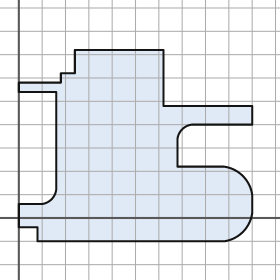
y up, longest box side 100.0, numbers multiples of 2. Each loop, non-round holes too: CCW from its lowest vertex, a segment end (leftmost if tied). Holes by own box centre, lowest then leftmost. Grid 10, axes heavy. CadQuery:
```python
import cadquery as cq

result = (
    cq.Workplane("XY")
    .moveTo(8.0, -10.0)
    .lineTo(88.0, -10.0)
    .threePointArc((96.0, -6.0), (100.0, 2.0))
    .lineTo(100.0, 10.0)
    .threePointArc((96.0, 18.0), (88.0, 22.0))
    .lineTo(68.0, 22.0)
    .lineTo(68.0, 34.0)
    .threePointArc((70.0, 38.0), (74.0, 40.0))
    .lineTo(100.0, 40.0)
    .lineTo(100.0, 48.0)
    .lineTo(62.0, 48.0)
    .lineTo(62.0, 72.0)
    .lineTo(24.0, 72.0)
    .lineTo(24.0, 62.0)
    .lineTo(18.0, 62.0)
    .lineTo(18.0, 58.0)
    .lineTo(0.0, 58.0)
    .lineTo(0.0, 54.0)
    .lineTo(16.0, 54.0)
    .lineTo(16.0, 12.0)
    .threePointArc((14.0, 8.0), (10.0, 6.0))
    .lineTo(0.0, 6.0)
    .lineTo(0.0, -4.0)
    .lineTo(8.0, -4.0)
    .close()
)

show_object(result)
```